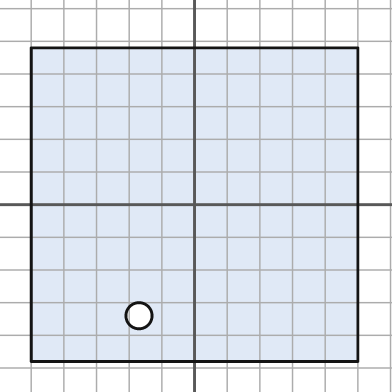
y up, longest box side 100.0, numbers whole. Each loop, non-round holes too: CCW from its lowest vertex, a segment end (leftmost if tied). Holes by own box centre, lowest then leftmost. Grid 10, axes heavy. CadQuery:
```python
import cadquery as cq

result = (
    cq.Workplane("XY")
    .moveTo(-50.0, -48.0)
    .lineTo(50.0, -48.0)
    .lineTo(50.0, 48.0)
    .lineTo(-50.0, 48.0)
    .close()
    .moveTo(-17.0, -34.0)
    .circle(4.0)
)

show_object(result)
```